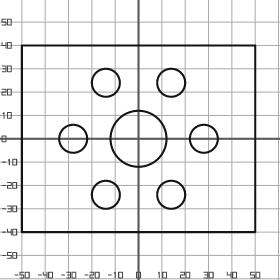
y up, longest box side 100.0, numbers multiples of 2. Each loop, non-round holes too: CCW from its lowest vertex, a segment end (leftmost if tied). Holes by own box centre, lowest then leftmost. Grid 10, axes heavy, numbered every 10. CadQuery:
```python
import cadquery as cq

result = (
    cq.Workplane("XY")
    .moveTo(-50.0, -40.0)
    .lineTo(50.0, -40.0)
    .lineTo(50.0, 40.0)
    .lineTo(-50.0, 40.0)
    .close()
    .moveTo(-14.0, -24.0)
    .circle(6.0)
    .moveTo(14.0, -24.0)
    .circle(6.0)
    .moveTo(-28.0, 0.0)
    .circle(6.0)
    .moveTo(0.0, 0.0)
    .circle(12.0)
    .moveTo(28.0, 0.0)
    .circle(6.0)
    .moveTo(-14.0, 24.0)
    .circle(6.0)
    .moveTo(14.0, 24.0)
    .circle(6.0)
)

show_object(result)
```